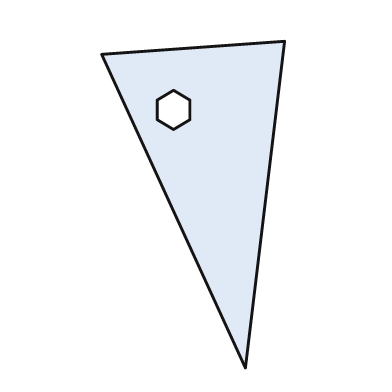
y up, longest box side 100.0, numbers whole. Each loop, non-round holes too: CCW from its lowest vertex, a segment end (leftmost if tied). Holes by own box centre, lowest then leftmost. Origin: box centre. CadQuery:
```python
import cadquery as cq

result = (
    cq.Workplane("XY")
    .moveTo(16.0, -50.0)
    .lineTo(28.0, 50.0)
    .lineTo(-28.0, 46.0)
    .close()
    .moveTo(-6.0, 23.0)
    .lineTo(-1.0, 26.0)
    .lineTo(-1.0, 32.0)
    .lineTo(-6.0, 35.0)
    .lineTo(-11.0, 32.0)
    .lineTo(-11.0, 26.0)
    .close()
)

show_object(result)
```